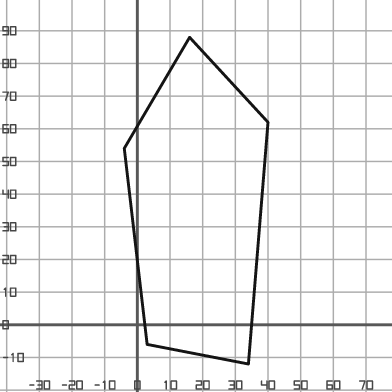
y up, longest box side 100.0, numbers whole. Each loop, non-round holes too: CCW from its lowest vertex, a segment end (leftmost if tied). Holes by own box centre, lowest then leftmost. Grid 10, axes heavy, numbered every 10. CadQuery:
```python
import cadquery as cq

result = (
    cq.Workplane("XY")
    .moveTo(34.0, -12.0)
    .lineTo(40.0, 62.0)
    .lineTo(16.0, 88.0)
    .lineTo(-4.0, 54.0)
    .lineTo(3.0, -6.0)
    .close()
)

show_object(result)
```